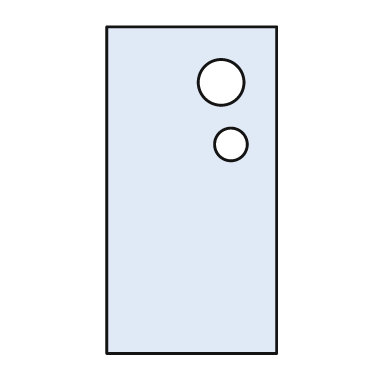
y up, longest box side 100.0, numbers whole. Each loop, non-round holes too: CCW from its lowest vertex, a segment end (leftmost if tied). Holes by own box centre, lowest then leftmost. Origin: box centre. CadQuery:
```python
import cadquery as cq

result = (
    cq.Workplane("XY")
    .moveTo(-26.0, -50.0)
    .lineTo(26.0, -50.0)
    .lineTo(26.0, 50.0)
    .lineTo(-26.0, 50.0)
    .close()
    .moveTo(12.0, 14.0)
    .circle(5.0)
    .moveTo(9.0, 33.0)
    .circle(7.0)
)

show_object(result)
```